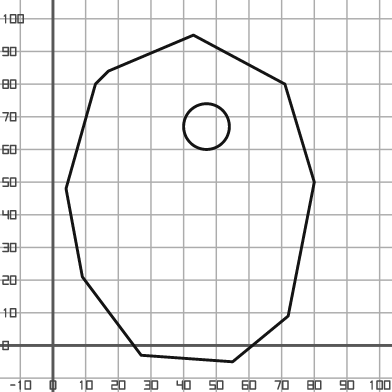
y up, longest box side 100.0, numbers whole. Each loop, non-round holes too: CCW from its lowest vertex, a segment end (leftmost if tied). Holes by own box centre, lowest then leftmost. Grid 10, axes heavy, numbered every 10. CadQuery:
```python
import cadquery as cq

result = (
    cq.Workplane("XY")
    .moveTo(55.0, -5.0)
    .lineTo(72.0, 9.0)
    .lineTo(80.0, 50.0)
    .lineTo(71.0, 80.0)
    .lineTo(43.0, 95.0)
    .lineTo(17.0, 84.0)
    .lineTo(13.0, 80.0)
    .lineTo(4.0, 48.0)
    .lineTo(9.0, 21.0)
    .lineTo(27.0, -3.0)
    .close()
    .moveTo(47.0, 67.0)
    .circle(7.0)
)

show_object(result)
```